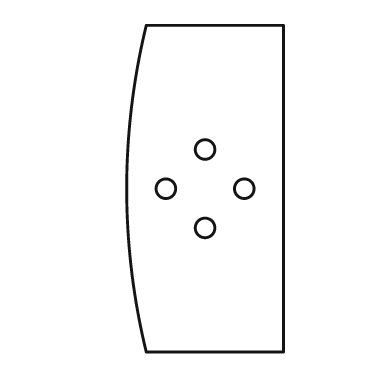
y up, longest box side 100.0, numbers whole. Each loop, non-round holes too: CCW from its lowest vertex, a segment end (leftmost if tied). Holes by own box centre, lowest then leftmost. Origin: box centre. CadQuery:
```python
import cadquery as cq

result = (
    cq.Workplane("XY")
    .moveTo(-18.0, -50.0)
    .lineTo(24.0, -50.0)
    .lineTo(24.0, 50.0)
    .lineTo(-18.0, 50.0)
    .threePointArc((-24.0, 0.0), (-18.0, -50.0))
    .close()
    .moveTo(0.0, -12.0)
    .circle(3.0)
    .moveTo(-12.0, 0.0)
    .circle(3.0)
    .moveTo(12.0, 0.0)
    .circle(3.0)
    .moveTo(0.0, 12.0)
    .circle(3.0)
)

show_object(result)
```